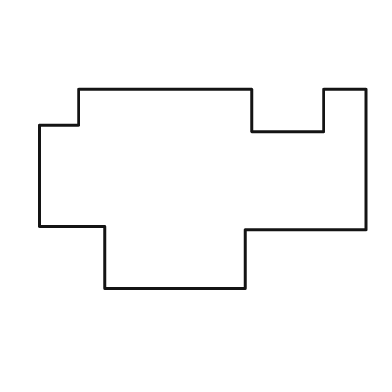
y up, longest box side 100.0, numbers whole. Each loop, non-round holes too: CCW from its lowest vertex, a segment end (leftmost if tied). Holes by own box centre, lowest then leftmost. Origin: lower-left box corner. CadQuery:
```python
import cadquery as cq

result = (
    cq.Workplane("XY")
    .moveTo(20.0, 0.0)
    .lineTo(63.0, 0.0)
    .lineTo(63.0, 18.0)
    .lineTo(100.0, 18.0)
    .lineTo(100.0, 61.0)
    .lineTo(87.0, 61.0)
    .lineTo(87.0, 48.0)
    .lineTo(65.0, 48.0)
    .lineTo(65.0, 61.0)
    .lineTo(12.0, 61.0)
    .lineTo(12.0, 50.0)
    .lineTo(0.0, 50.0)
    .lineTo(0.0, 19.0)
    .lineTo(20.0, 19.0)
    .close()
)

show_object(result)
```